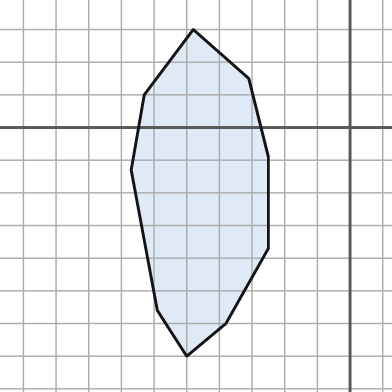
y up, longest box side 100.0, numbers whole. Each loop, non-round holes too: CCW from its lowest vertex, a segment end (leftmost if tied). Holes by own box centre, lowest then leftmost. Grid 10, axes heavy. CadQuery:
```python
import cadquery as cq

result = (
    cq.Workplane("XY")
    .moveTo(-50.0, -70.0)
    .lineTo(-38.0, -60.0)
    .lineTo(-25.0, -37.0)
    .lineTo(-25.0, -9.0)
    .lineTo(-31.0, 15.0)
    .lineTo(-48.0, 30.0)
    .lineTo(-63.0, 10.0)
    .lineTo(-67.0, -13.0)
    .lineTo(-59.0, -56.0)
    .close()
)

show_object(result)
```